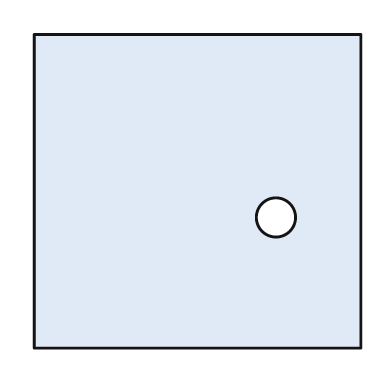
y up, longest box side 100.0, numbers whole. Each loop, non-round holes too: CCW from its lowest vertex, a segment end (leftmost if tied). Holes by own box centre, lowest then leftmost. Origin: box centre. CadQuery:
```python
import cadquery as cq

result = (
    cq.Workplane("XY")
    .moveTo(-50.0, -48.0)
    .lineTo(50.0, -48.0)
    .lineTo(50.0, 48.0)
    .lineTo(-50.0, 48.0)
    .close()
    .moveTo(24.0, -8.0)
    .circle(6.0)
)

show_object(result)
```